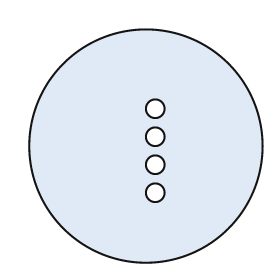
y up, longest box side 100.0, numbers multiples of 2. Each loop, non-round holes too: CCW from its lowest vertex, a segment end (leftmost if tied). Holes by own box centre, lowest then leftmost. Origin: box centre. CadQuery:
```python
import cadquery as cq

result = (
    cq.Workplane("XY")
    .moveTo(0.0, 0.0)
    .circle(50.0)
    .moveTo(4.0, -20.0)
    .circle(4.0)
    .moveTo(4.0, -8.0)
    .circle(4.0)
    .moveTo(4.0, 4.0)
    .circle(4.0)
    .moveTo(4.0, 16.0)
    .circle(4.0)
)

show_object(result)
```